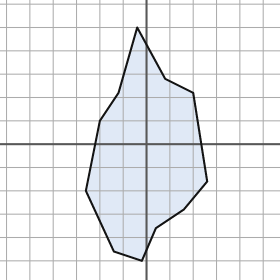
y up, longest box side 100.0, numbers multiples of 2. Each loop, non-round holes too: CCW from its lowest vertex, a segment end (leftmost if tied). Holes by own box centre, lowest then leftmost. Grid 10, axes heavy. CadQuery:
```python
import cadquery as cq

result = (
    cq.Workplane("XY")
    .moveTo(-2.0, -50.0)
    .lineTo(4.0, -36.0)
    .lineTo(16.0, -28.0)
    .lineTo(26.0, -16.0)
    .lineTo(20.0, 22.0)
    .lineTo(8.0, 28.0)
    .lineTo(-4.0, 50.0)
    .lineTo(-12.0, 22.0)
    .lineTo(-20.0, 10.0)
    .lineTo(-26.0, -20.0)
    .lineTo(-14.0, -46.0)
    .close()
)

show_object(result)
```